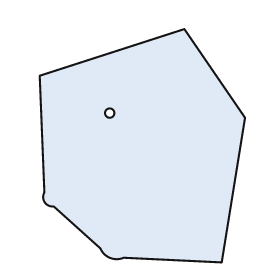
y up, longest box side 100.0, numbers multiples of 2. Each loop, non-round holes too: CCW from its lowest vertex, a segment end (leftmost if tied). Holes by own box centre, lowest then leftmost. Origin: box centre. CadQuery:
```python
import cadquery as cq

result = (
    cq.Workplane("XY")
    .moveTo(34.0, -50.0)
    .lineTo(44.0, 12.0)
    .lineTo(18.0, 50.0)
    .lineTo(-44.0, 30.0)
    .lineTo(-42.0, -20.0)
    .threePointArc((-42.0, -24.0), (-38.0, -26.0))
    .lineTo(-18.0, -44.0)
    .threePointArc((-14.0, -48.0), (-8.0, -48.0))
    .close()
    .moveTo(-14.0, 14.0)
    .circle(2.0)
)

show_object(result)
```